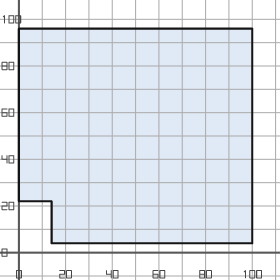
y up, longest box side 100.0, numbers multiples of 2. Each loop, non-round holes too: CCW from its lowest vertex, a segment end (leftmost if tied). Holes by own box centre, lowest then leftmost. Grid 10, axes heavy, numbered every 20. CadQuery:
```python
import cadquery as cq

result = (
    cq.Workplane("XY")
    .moveTo(14.0, 4.0)
    .lineTo(100.0, 4.0)
    .lineTo(100.0, 96.0)
    .lineTo(0.0, 96.0)
    .lineTo(0.0, 22.0)
    .lineTo(14.0, 22.0)
    .close()
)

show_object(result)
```